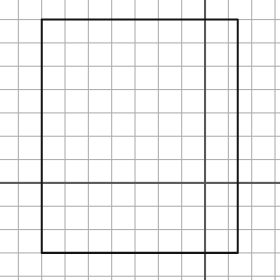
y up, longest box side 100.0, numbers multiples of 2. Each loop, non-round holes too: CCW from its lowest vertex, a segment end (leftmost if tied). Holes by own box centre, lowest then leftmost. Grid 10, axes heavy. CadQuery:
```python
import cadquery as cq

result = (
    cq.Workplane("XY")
    .moveTo(-70.0, -30.0)
    .lineTo(14.0, -30.0)
    .lineTo(14.0, 70.0)
    .lineTo(-70.0, 70.0)
    .close()
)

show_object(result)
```